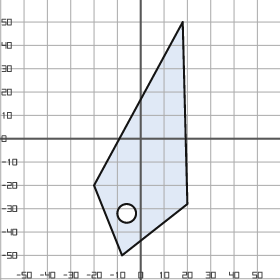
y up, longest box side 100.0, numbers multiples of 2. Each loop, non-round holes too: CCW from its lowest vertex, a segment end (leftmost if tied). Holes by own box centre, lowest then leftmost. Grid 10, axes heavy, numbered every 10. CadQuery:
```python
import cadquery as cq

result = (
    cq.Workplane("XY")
    .moveTo(-8.0, -50.0)
    .lineTo(20.0, -28.0)
    .lineTo(18.0, 50.0)
    .lineTo(-20.0, -20.0)
    .close()
    .moveTo(-6.0, -32.0)
    .circle(4.0)
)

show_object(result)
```